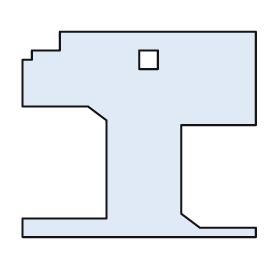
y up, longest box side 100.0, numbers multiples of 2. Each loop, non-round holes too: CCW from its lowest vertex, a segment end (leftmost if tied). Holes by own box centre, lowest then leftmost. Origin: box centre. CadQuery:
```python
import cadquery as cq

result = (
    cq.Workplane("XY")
    .moveTo(-50.0, -44.0)
    .lineTo(50.0, -44.0)
    .lineTo(50.0, -40.0)
    .lineTo(26.0, -40.0)
    .lineTo(18.0, -34.0)
    .lineTo(18.0, 4.0)
    .lineTo(50.0, 4.0)
    .lineTo(50.0, 44.0)
    .lineTo(-34.0, 44.0)
    .lineTo(-34.0, 36.0)
    .lineTo(-46.0, 36.0)
    .lineTo(-46.0, 32.0)
    .lineTo(-50.0, 32.0)
    .lineTo(-50.0, 12.0)
    .lineTo(-22.0, 12.0)
    .lineTo(-14.0, 6.0)
    .lineTo(-14.0, -36.0)
    .lineTo(-50.0, -36.0)
    .close()
    .moveTo(0.0, 28.0)
    .lineTo(8.0, 28.0)
    .lineTo(8.0, 36.0)
    .lineTo(0.0, 36.0)
    .close()
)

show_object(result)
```